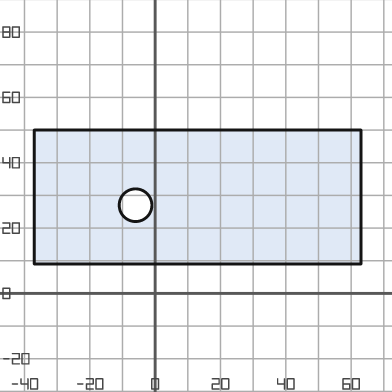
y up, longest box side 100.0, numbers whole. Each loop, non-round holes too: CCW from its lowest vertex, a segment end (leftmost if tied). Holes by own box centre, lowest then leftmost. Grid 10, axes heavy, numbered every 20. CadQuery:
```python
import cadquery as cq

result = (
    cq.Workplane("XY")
    .moveTo(-37.0, 9.0)
    .lineTo(63.0, 9.0)
    .lineTo(63.0, 50.0)
    .lineTo(-37.0, 50.0)
    .close()
    .moveTo(-6.0, 27.0)
    .circle(5.0)
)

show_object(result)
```